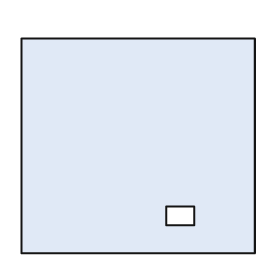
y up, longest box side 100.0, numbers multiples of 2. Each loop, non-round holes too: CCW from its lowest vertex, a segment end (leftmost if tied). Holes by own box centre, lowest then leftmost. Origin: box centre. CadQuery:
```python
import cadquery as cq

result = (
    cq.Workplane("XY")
    .moveTo(-50.0, -46.0)
    .lineTo(50.0, -46.0)
    .lineTo(50.0, 46.0)
    .lineTo(-50.0, 46.0)
    .close()
    .moveTo(12.0, -34.0)
    .lineTo(24.0, -34.0)
    .lineTo(24.0, -26.0)
    .lineTo(12.0, -26.0)
    .close()
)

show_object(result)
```